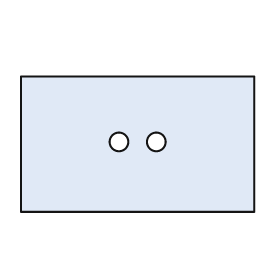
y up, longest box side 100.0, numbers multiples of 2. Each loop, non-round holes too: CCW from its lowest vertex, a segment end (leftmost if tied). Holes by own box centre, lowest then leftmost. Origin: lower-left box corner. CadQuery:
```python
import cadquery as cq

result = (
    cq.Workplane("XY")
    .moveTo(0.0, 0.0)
    .lineTo(100.0, 0.0)
    .lineTo(100.0, 58.0)
    .lineTo(0.0, 58.0)
    .close()
    .moveTo(42.0, 30.0)
    .circle(4.0)
    .moveTo(58.0, 30.0)
    .circle(4.0)
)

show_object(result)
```